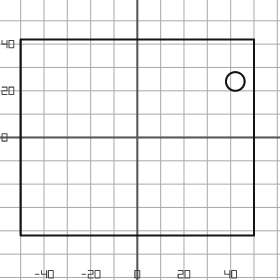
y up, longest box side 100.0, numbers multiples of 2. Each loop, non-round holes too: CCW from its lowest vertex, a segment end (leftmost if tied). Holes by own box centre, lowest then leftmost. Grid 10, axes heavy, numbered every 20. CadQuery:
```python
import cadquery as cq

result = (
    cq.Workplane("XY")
    .moveTo(-50.0, -42.0)
    .lineTo(50.0, -42.0)
    .lineTo(50.0, 42.0)
    .lineTo(-50.0, 42.0)
    .close()
    .moveTo(42.0, 24.0)
    .circle(4.0)
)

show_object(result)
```